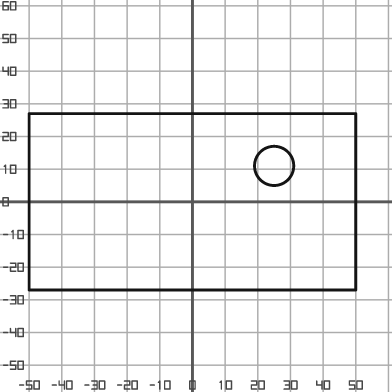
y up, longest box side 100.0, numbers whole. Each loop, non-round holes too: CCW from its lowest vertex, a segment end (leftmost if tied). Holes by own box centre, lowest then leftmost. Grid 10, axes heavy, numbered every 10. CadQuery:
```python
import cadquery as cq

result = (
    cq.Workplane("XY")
    .moveTo(-50.0, -27.0)
    .lineTo(50.0, -27.0)
    .lineTo(50.0, 27.0)
    .lineTo(-50.0, 27.0)
    .close()
    .moveTo(25.0, 11.0)
    .circle(6.0)
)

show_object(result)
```